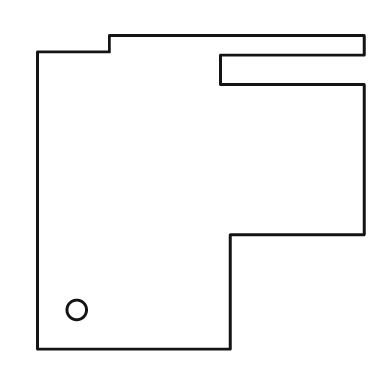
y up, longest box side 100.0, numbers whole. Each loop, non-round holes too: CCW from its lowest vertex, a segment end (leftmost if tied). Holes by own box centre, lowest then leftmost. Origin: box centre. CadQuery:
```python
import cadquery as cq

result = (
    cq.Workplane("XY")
    .moveTo(-50.0, -48.0)
    .lineTo(9.0, -48.0)
    .lineTo(9.0, -13.0)
    .lineTo(50.0, -13.0)
    .lineTo(50.0, 33.0)
    .lineTo(6.0, 33.0)
    .lineTo(6.0, 42.0)
    .lineTo(50.0, 42.0)
    .lineTo(50.0, 48.0)
    .lineTo(-28.0, 48.0)
    .lineTo(-28.0, 43.0)
    .lineTo(-50.0, 43.0)
    .close()
    .moveTo(-38.0, -36.0)
    .circle(3.0)
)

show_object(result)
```